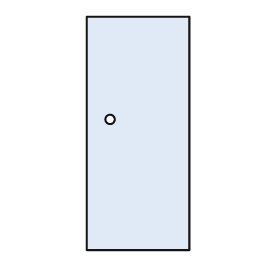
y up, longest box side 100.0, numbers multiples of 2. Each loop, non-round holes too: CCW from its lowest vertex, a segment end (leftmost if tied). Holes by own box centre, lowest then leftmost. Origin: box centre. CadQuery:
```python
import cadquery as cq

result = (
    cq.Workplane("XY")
    .moveTo(-22.0, -50.0)
    .lineTo(22.0, -50.0)
    .lineTo(22.0, 50.0)
    .lineTo(-22.0, 50.0)
    .close()
    .moveTo(-12.0, 6.0)
    .circle(2.0)
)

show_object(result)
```